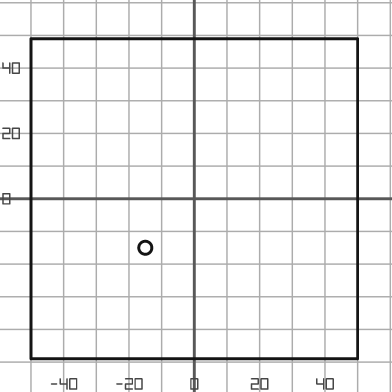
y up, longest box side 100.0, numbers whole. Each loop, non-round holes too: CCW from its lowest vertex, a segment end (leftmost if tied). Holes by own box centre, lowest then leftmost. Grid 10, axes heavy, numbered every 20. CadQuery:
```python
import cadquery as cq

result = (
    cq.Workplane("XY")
    .moveTo(-50.0, -49.0)
    .lineTo(50.0, -49.0)
    .lineTo(50.0, 49.0)
    .lineTo(-50.0, 49.0)
    .close()
    .moveTo(-15.0, -15.0)
    .circle(2.0)
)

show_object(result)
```